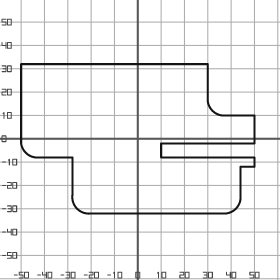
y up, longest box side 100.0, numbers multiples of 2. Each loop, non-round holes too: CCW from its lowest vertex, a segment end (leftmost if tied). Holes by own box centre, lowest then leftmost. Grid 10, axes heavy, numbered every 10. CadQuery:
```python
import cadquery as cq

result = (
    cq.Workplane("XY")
    .moveTo(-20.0, -32.0)
    .lineTo(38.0, -32.0)
    .threePointArc((42.0, -30.0), (44.0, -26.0))
    .lineTo(44.0, -12.0)
    .lineTo(50.0, -12.0)
    .lineTo(50.0, -8.0)
    .lineTo(10.0, -8.0)
    .lineTo(10.0, -2.0)
    .lineTo(50.0, -2.0)
    .lineTo(50.0, 10.0)
    .lineTo(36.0, 10.0)
    .threePointArc((32.0, 12.0), (30.0, 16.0))
    .lineTo(30.0, 32.0)
    .lineTo(-50.0, 32.0)
    .lineTo(-50.0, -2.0)
    .threePointArc((-48.0, -6.0), (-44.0, -8.0))
    .lineTo(-28.0, -8.0)
    .lineTo(-28.0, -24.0)
    .threePointArc((-26.0, -30.0), (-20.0, -32.0))
    .close()
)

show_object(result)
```